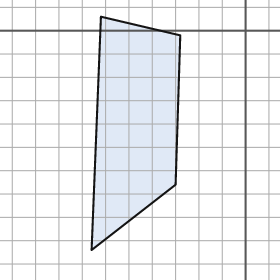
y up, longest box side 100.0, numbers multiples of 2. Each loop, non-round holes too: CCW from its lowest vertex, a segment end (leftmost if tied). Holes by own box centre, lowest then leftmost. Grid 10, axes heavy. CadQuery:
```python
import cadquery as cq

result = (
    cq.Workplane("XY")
    .moveTo(-66.0, -94.0)
    .lineTo(-30.0, -66.0)
    .lineTo(-28.0, -2.0)
    .lineTo(-62.0, 6.0)
    .close()
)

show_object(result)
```